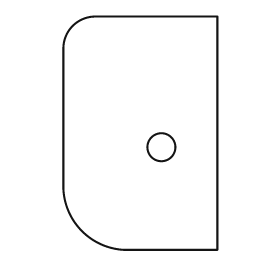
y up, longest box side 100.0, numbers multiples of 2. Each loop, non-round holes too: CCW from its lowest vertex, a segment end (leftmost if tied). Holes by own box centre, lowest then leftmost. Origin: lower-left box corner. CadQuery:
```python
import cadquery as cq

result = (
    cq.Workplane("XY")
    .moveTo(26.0, 0.0)
    .lineTo(66.0, 0.0)
    .lineTo(66.0, 100.0)
    .lineTo(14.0, 100.0)
    .threePointArc((4.0, 96.0), (0.0, 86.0))
    .lineTo(0.0, 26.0)
    .threePointArc((8.0, 8.0), (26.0, 0.0))
    .close()
    .moveTo(42.0, 44.0)
    .circle(6.0)
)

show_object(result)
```